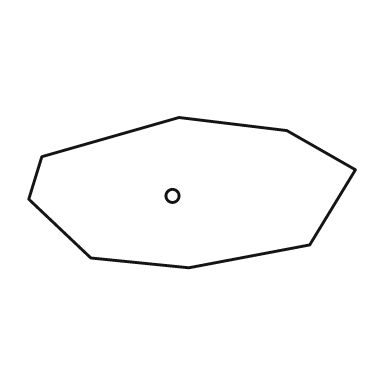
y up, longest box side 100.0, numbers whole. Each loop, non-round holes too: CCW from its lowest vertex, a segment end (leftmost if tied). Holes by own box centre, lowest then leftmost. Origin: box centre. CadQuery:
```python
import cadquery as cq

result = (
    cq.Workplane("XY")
    .moveTo(-1.0, -23.0)
    .lineTo(36.0, -16.0)
    .lineTo(50.0, 7.0)
    .lineTo(29.0, 19.0)
    .lineTo(-4.0, 23.0)
    .lineTo(-46.0, 11.0)
    .lineTo(-50.0, -2.0)
    .lineTo(-31.0, -20.0)
    .close()
    .moveTo(-6.0, -1.0)
    .circle(2.0)
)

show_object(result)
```